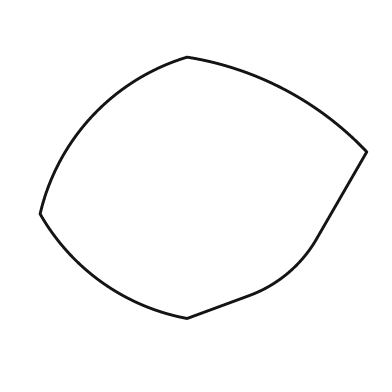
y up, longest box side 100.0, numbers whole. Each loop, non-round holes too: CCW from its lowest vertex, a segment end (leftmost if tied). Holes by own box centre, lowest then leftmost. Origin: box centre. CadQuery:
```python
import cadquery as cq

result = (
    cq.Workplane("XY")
    .moveTo(-5.0, -40.0)
    .lineTo(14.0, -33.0)
    .threePointArc((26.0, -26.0), (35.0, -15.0))
    .lineTo(50.0, 11.0)
    .threePointArc((25.0, 30.0), (-5.0, 40.0))
    .threePointArc((-34.0, 22.0), (-50.0, -8.0))
    .threePointArc((-31.0, -29.0), (-5.0, -40.0))
    .close()
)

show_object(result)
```